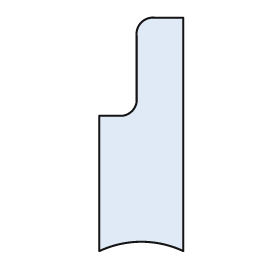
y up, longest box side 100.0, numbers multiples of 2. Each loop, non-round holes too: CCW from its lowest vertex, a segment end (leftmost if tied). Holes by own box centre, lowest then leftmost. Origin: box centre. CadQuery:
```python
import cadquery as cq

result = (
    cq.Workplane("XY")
    .moveTo(-18.0, -50.0)
    .threePointArc((0.0, -46.0), (18.0, -50.0))
    .lineTo(18.0, 50.0)
    .lineTo(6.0, 50.0)
    .threePointArc((0.0, 48.0), (-2.0, 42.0))
    .lineTo(-2.0, 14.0)
    .threePointArc((-4.0, 10.0), (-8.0, 8.0))
    .lineTo(-18.0, 8.0)
    .close()
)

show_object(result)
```